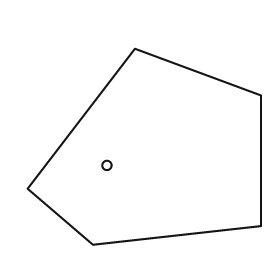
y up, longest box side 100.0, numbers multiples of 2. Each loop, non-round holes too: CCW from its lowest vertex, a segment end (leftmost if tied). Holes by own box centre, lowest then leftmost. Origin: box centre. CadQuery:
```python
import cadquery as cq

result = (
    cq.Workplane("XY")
    .moveTo(-22.0, -42.0)
    .lineTo(50.0, -34.0)
    .lineTo(50.0, 22.0)
    .lineTo(-4.0, 42.0)
    .lineTo(-50.0, -18.0)
    .close()
    .moveTo(-16.0, -8.0)
    .circle(2.0)
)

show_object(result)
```